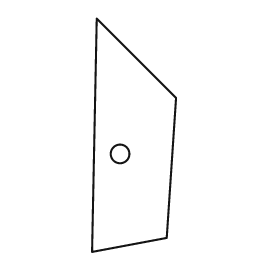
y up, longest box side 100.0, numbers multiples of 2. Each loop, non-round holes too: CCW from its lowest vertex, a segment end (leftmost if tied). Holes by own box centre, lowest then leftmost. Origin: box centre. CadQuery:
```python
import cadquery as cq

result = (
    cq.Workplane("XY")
    .moveTo(-18.0, -50.0)
    .lineTo(14.0, -44.0)
    .lineTo(18.0, 16.0)
    .lineTo(-16.0, 50.0)
    .close()
    .moveTo(-6.0, -8.0)
    .circle(4.0)
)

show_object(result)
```